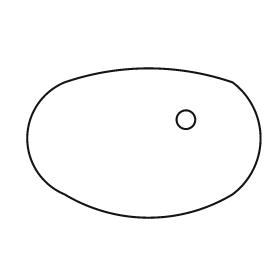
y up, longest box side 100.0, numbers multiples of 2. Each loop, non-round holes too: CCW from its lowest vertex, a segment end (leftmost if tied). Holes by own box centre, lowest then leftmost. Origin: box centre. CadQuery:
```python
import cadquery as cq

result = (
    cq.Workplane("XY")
    .moveTo(-34.0, -22.0)
    .threePointArc((2.0, -32.0), (38.0, -22.0))
    .threePointArc((50.0, 2.0), (38.0, 26.0))
    .threePointArc((2.0, 32.0), (-34.0, 26.0))
    .threePointArc((-50.0, 2.0), (-34.0, -22.0))
    .close()
    .moveTo(18.0, 10.0)
    .circle(4.0)
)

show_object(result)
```